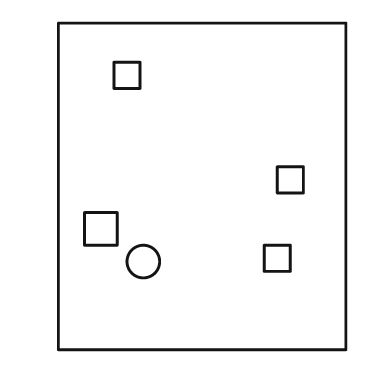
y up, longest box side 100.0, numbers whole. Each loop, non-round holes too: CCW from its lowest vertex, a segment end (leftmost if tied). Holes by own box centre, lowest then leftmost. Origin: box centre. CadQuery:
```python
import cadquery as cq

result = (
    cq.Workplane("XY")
    .moveTo(-44.0, -50.0)
    .lineTo(44.0, -50.0)
    .lineTo(44.0, 50.0)
    .lineTo(-44.0, 50.0)
    .close()
    .moveTo(-18.0, -23.0)
    .circle(5.0)
    .moveTo(19.0, -26.0)
    .lineTo(27.0, -26.0)
    .lineTo(27.0, -18.0)
    .lineTo(19.0, -18.0)
    .close()
    .moveTo(-36.0, -18.0)
    .lineTo(-26.0, -18.0)
    .lineTo(-26.0, -8.0)
    .lineTo(-36.0, -8.0)
    .close()
    .moveTo(23.0, -2.0)
    .lineTo(31.0, -2.0)
    .lineTo(31.0, 6.0)
    .lineTo(23.0, 6.0)
    .close()
    .moveTo(-27.0, 30.0)
    .lineTo(-19.0, 30.0)
    .lineTo(-19.0, 38.0)
    .lineTo(-27.0, 38.0)
    .close()
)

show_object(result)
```